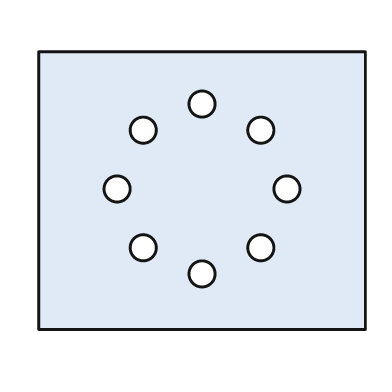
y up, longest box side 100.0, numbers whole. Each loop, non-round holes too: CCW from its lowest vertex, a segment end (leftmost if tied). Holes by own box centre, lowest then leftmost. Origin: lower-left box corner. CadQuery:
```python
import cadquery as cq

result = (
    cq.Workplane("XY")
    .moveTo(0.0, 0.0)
    .lineTo(100.0, 0.0)
    .lineTo(100.0, 85.0)
    .lineTo(0.0, 85.0)
    .close()
    .moveTo(50.0, 17.0)
    .circle(4.0)
    .moveTo(32.0, 25.0)
    .circle(4.0)
    .moveTo(68.0, 25.0)
    .circle(4.0)
    .moveTo(24.0, 43.0)
    .circle(4.0)
    .moveTo(76.0, 43.0)
    .circle(4.0)
    .moveTo(32.0, 61.0)
    .circle(4.0)
    .moveTo(68.0, 61.0)
    .circle(4.0)
    .moveTo(50.0, 69.0)
    .circle(4.0)
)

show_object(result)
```